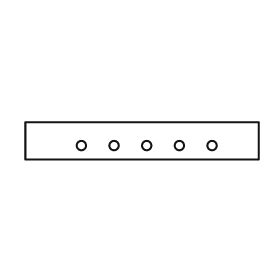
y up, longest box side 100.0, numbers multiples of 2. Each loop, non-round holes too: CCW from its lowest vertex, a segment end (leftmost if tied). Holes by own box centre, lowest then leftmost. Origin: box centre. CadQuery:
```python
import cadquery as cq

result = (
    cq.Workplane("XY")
    .moveTo(-50.0, -8.0)
    .lineTo(50.0, -8.0)
    .lineTo(50.0, 8.0)
    .lineTo(-50.0, 8.0)
    .close()
    .moveTo(-26.0, -2.0)
    .circle(2.0)
    .moveTo(-12.0, -2.0)
    .circle(2.0)
    .moveTo(2.0, -2.0)
    .circle(2.0)
    .moveTo(16.0, -2.0)
    .circle(2.0)
    .moveTo(30.0, -2.0)
    .circle(2.0)
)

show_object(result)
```